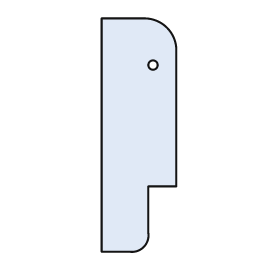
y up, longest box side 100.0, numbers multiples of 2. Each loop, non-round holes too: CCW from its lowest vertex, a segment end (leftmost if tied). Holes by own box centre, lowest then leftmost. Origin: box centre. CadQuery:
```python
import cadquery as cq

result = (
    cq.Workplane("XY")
    .moveTo(-16.0, -50.0)
    .lineTo(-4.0, -50.0)
    .threePointArc((2.0, -48.0), (4.0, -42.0))
    .lineTo(4.0, -22.0)
    .lineTo(16.0, -22.0)
    .lineTo(16.0, 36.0)
    .threePointArc((12.0, 46.0), (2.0, 50.0))
    .lineTo(-16.0, 50.0)
    .close()
    .moveTo(6.0, 30.0)
    .circle(2.0)
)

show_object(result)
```